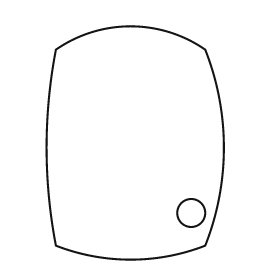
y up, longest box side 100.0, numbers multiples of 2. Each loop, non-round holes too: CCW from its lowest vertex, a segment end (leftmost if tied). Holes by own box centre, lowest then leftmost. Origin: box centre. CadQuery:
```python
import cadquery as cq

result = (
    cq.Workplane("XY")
    .moveTo(-34.0, -44.0)
    .threePointArc((-2.0, -50.0), (30.0, -44.0))
    .threePointArc((38.0, -2.0), (30.0, 40.0))
    .threePointArc((-2.0, 50.0), (-34.0, 40.0))
    .threePointArc((-38.0, -2.0), (-34.0, -44.0))
    .close()
    .moveTo(24.0, -30.0)
    .circle(6.0)
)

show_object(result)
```